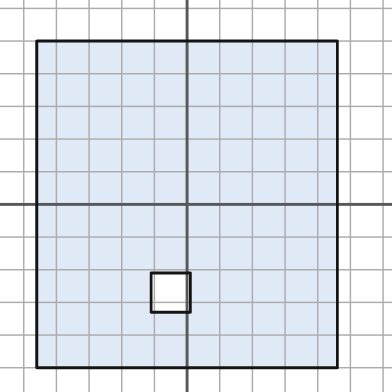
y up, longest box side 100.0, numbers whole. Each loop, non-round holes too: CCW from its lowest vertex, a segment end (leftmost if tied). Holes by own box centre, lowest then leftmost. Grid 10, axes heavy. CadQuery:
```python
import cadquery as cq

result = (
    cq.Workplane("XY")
    .moveTo(-46.0, -50.0)
    .lineTo(46.0, -50.0)
    .lineTo(46.0, 50.0)
    .lineTo(-46.0, 50.0)
    .close()
    .moveTo(-11.0, -33.0)
    .lineTo(1.0, -33.0)
    .lineTo(1.0, -21.0)
    .lineTo(-11.0, -21.0)
    .close()
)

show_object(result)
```